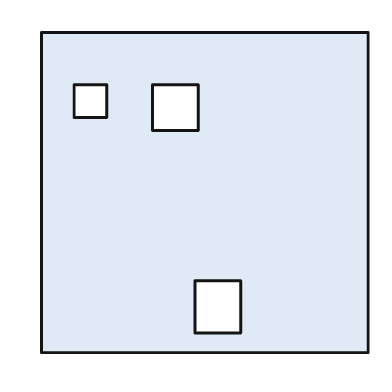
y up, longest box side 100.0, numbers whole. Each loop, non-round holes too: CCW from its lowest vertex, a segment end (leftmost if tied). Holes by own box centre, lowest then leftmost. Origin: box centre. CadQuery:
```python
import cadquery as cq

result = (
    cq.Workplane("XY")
    .moveTo(-50.0, -49.0)
    .lineTo(50.0, -49.0)
    .lineTo(50.0, 49.0)
    .lineTo(-50.0, 49.0)
    .close()
    .moveTo(-3.0, -43.0)
    .lineTo(11.0, -43.0)
    .lineTo(11.0, -27.0)
    .lineTo(-3.0, -27.0)
    .close()
    .moveTo(-16.0, 19.0)
    .lineTo(-2.0, 19.0)
    .lineTo(-2.0, 33.0)
    .lineTo(-16.0, 33.0)
    .close()
    .moveTo(-40.0, 23.0)
    .lineTo(-30.0, 23.0)
    .lineTo(-30.0, 33.0)
    .lineTo(-40.0, 33.0)
    .close()
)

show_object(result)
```